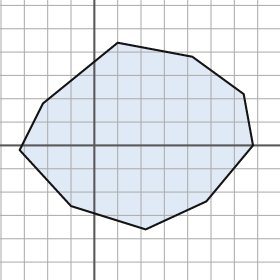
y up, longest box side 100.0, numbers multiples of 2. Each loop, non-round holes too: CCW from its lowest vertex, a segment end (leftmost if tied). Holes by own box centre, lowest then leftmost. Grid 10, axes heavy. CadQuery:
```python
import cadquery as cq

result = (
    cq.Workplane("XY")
    .moveTo(22.0, -36.0)
    .lineTo(48.0, -24.0)
    .lineTo(68.0, 0.0)
    .lineTo(64.0, 22.0)
    .lineTo(42.0, 38.0)
    .lineTo(10.0, 44.0)
    .lineTo(-22.0, 18.0)
    .lineTo(-32.0, -2.0)
    .lineTo(-10.0, -26.0)
    .close()
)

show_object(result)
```